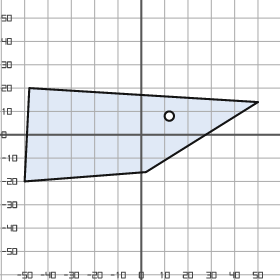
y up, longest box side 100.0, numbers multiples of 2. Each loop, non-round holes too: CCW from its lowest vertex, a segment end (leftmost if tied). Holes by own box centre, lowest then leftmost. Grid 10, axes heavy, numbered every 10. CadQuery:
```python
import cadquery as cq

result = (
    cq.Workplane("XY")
    .moveTo(-50.0, -20.0)
    .lineTo(2.0, -16.0)
    .lineTo(50.0, 14.0)
    .lineTo(-48.0, 20.0)
    .close()
    .moveTo(12.0, 8.0)
    .circle(2.0)
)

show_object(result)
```